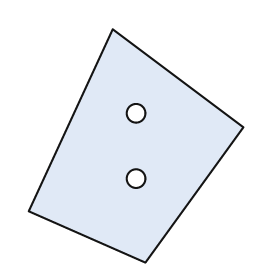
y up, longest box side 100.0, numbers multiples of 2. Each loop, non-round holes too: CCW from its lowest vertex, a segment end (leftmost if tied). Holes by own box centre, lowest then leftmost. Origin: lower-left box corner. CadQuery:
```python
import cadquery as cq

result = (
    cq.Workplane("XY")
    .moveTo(50.0, 0.0)
    .lineTo(92.0, 58.0)
    .lineTo(36.0, 100.0)
    .lineTo(0.0, 22.0)
    .close()
    .moveTo(46.0, 36.0)
    .circle(4.0)
    .moveTo(46.0, 64.0)
    .circle(4.0)
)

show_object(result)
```